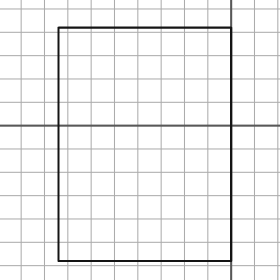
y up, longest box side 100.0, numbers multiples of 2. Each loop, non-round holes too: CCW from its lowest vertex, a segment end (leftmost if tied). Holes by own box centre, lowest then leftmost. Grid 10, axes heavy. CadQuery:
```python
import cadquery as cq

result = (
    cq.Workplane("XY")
    .moveTo(-74.0, -58.0)
    .lineTo(0.0, -58.0)
    .lineTo(0.0, 42.0)
    .lineTo(-74.0, 42.0)
    .close()
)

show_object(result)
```